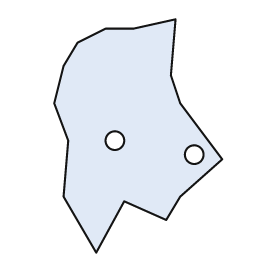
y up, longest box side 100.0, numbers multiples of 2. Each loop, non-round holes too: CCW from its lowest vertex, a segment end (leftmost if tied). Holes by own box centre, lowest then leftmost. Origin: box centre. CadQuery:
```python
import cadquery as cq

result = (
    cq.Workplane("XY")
    .moveTo(-18.0, -50.0)
    .lineTo(-6.0, -28.0)
    .lineTo(12.0, -36.0)
    .lineTo(18.0, -26.0)
    .lineTo(36.0, -10.0)
    .lineTo(18.0, 14.0)
    .lineTo(14.0, 26.0)
    .lineTo(16.0, 50.0)
    .lineTo(-2.0, 46.0)
    .lineTo(-14.0, 46.0)
    .lineTo(-26.0, 40.0)
    .lineTo(-32.0, 30.0)
    .lineTo(-36.0, 14.0)
    .lineTo(-30.0, -2.0)
    .lineTo(-32.0, -26.0)
    .close()
    .moveTo(24.0, -8.0)
    .circle(4.0)
    .moveTo(-10.0, -2.0)
    .circle(4.0)
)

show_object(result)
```